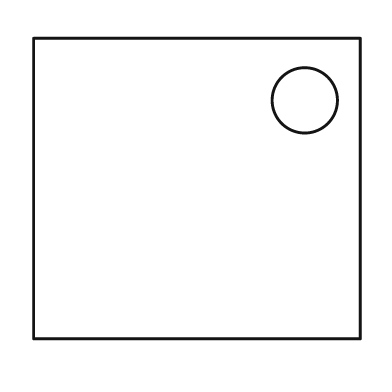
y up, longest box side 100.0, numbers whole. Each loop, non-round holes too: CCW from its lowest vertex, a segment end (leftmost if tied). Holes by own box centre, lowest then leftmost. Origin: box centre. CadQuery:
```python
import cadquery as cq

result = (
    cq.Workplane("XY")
    .moveTo(-50.0, -46.0)
    .lineTo(50.0, -46.0)
    .lineTo(50.0, 46.0)
    .lineTo(-50.0, 46.0)
    .close()
    .moveTo(33.0, 27.0)
    .circle(10.0)
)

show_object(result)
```